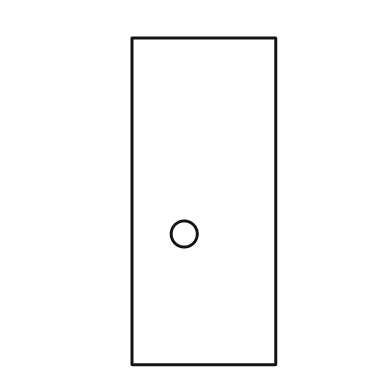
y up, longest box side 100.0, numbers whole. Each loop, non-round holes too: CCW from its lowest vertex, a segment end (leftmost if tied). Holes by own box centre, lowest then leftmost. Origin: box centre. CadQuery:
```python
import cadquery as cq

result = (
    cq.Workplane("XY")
    .moveTo(-22.0, -50.0)
    .lineTo(22.0, -50.0)
    .lineTo(22.0, 50.0)
    .lineTo(-22.0, 50.0)
    .close()
    .moveTo(-6.0, -10.0)
    .circle(4.0)
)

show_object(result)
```